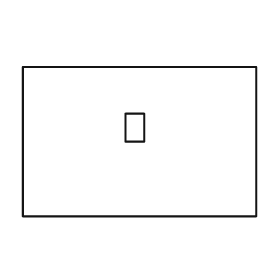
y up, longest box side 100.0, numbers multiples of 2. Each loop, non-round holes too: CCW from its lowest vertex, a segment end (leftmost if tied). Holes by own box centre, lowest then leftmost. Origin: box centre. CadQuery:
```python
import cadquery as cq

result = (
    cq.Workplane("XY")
    .moveTo(-50.0, -32.0)
    .lineTo(50.0, -32.0)
    .lineTo(50.0, 32.0)
    .lineTo(-50.0, 32.0)
    .close()
    .moveTo(-6.0, 0.0)
    .lineTo(2.0, 0.0)
    .lineTo(2.0, 12.0)
    .lineTo(-6.0, 12.0)
    .close()
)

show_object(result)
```